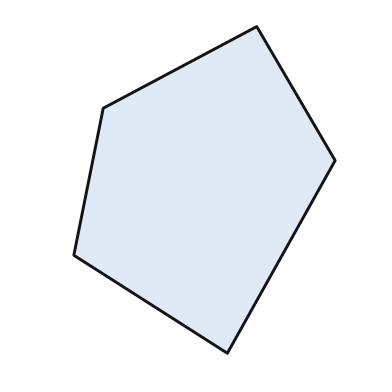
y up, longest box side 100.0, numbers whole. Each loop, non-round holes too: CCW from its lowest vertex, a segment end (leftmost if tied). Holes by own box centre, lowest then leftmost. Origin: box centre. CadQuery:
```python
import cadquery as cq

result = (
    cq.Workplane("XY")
    .moveTo(7.0, -50.0)
    .lineTo(40.0, 9.0)
    .lineTo(16.0, 50.0)
    .lineTo(-31.0, 25.0)
    .lineTo(-40.0, -20.0)
    .close()
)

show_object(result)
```